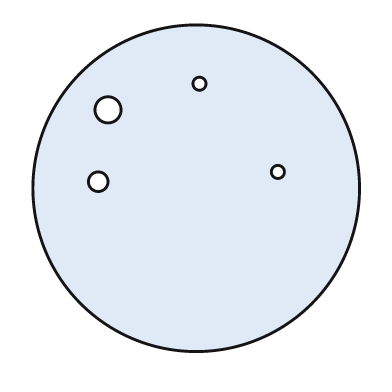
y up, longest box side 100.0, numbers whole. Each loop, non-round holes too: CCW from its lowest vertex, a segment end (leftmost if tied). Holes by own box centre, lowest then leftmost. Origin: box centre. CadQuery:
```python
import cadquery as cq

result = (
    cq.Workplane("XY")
    .moveTo(0.0, 0.0)
    .circle(50.0)
    .moveTo(-30.0, 2.0)
    .circle(3.0)
    .moveTo(25.0, 5.0)
    .circle(2.0)
    .moveTo(-27.0, 24.0)
    .circle(4.0)
    .moveTo(1.0, 32.0)
    .circle(2.0)
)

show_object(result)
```